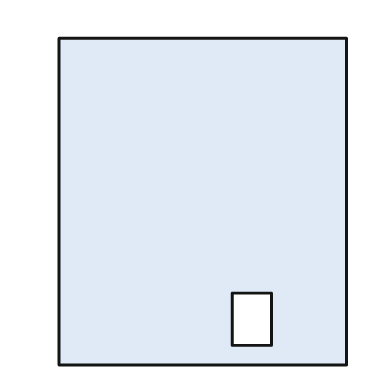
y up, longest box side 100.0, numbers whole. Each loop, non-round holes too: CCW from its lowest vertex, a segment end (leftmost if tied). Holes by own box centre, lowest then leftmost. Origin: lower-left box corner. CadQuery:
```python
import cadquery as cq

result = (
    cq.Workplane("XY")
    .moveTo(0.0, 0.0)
    .lineTo(88.0, 0.0)
    .lineTo(88.0, 100.0)
    .lineTo(0.0, 100.0)
    .close()
    .moveTo(53.0, 6.0)
    .lineTo(65.0, 6.0)
    .lineTo(65.0, 22.0)
    .lineTo(53.0, 22.0)
    .close()
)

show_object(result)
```